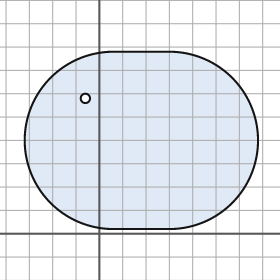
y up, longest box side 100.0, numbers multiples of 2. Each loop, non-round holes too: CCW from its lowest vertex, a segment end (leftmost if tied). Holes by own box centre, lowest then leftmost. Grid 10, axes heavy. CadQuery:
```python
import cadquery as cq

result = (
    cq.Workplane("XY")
    .moveTo(6.0, 2.0)
    .lineTo(30.0, 2.0)
    .threePointArc((68.0, 40.0), (30.0, 78.0))
    .lineTo(6.0, 78.0)
    .threePointArc((-32.0, 40.0), (6.0, 2.0))
    .close()
    .moveTo(-6.0, 58.0)
    .circle(2.0)
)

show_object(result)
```